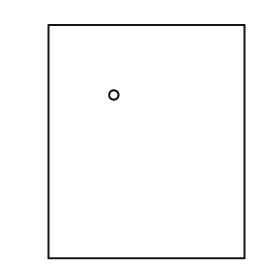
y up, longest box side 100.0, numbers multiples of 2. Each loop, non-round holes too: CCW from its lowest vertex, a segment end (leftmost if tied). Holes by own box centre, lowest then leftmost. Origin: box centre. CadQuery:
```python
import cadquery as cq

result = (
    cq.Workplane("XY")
    .moveTo(-42.0, -50.0)
    .lineTo(42.0, -50.0)
    .lineTo(42.0, 50.0)
    .lineTo(-42.0, 50.0)
    .close()
    .moveTo(-14.0, 20.0)
    .circle(2.0)
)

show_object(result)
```